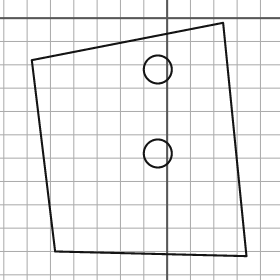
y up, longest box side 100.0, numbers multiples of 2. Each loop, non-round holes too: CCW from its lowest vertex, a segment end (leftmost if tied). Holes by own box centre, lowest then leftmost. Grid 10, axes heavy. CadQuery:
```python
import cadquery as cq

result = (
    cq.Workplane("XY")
    .moveTo(34.0, -102.0)
    .lineTo(24.0, -2.0)
    .lineTo(-58.0, -18.0)
    .lineTo(-48.0, -100.0)
    .close()
    .moveTo(-4.0, -58.0)
    .circle(6.0)
    .moveTo(-4.0, -22.0)
    .circle(6.0)
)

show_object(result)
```